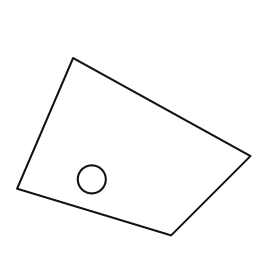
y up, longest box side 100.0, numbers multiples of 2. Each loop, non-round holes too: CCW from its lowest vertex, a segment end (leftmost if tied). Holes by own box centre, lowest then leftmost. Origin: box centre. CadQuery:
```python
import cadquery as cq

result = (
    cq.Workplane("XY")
    .moveTo(16.0, -38.0)
    .lineTo(50.0, -4.0)
    .lineTo(-26.0, 38.0)
    .lineTo(-50.0, -18.0)
    .close()
    .moveTo(-18.0, -14.0)
    .circle(6.0)
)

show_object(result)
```